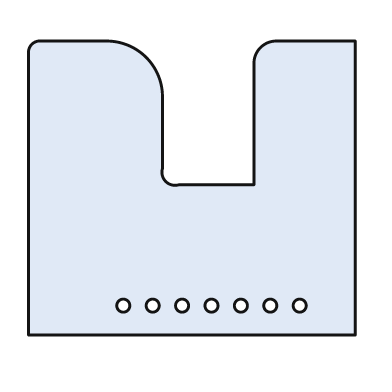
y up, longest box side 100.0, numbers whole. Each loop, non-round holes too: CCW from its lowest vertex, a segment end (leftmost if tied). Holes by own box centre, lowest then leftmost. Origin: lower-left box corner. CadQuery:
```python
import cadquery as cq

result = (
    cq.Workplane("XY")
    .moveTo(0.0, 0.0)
    .lineTo(100.0, 0.0)
    .lineTo(100.0, 90.0)
    .lineTo(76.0, 90.0)
    .threePointArc((71.0, 88.0), (69.0, 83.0))
    .lineTo(69.0, 46.0)
    .lineTo(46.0, 46.0)
    .threePointArc((42.0, 47.0), (41.0, 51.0))
    .lineTo(41.0, 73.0)
    .threePointArc((36.0, 85.0), (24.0, 90.0))
    .lineTo(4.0, 90.0)
    .threePointArc((1.0, 89.0), (0.0, 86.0))
    .close()
    .moveTo(29.0, 9.0)
    .circle(2.0)
    .moveTo(38.0, 9.0)
    .circle(2.0)
    .moveTo(47.0, 9.0)
    .circle(2.0)
    .moveTo(56.0, 9.0)
    .circle(2.0)
    .moveTo(65.0, 9.0)
    .circle(2.0)
    .moveTo(74.0, 9.0)
    .circle(2.0)
    .moveTo(83.0, 9.0)
    .circle(2.0)
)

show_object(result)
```